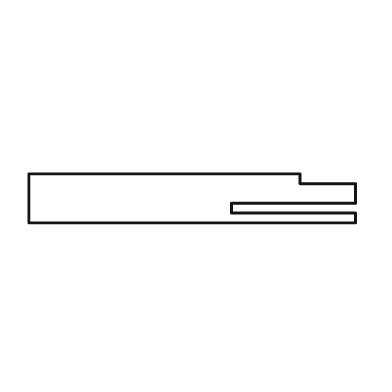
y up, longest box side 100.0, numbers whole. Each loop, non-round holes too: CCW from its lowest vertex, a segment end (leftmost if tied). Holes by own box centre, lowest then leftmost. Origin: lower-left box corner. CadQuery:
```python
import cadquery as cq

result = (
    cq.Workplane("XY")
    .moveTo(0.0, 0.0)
    .lineTo(100.0, 0.0)
    .lineTo(100.0, 3.0)
    .lineTo(62.0, 3.0)
    .lineTo(62.0, 6.0)
    .lineTo(100.0, 6.0)
    .lineTo(100.0, 12.0)
    .lineTo(83.0, 12.0)
    .lineTo(83.0, 15.0)
    .lineTo(0.0, 15.0)
    .close()
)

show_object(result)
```